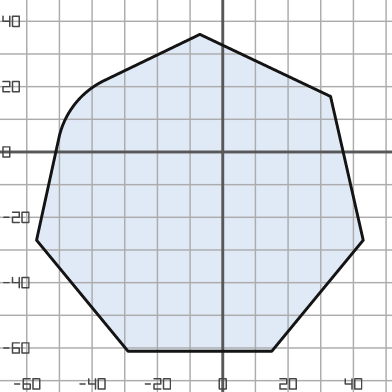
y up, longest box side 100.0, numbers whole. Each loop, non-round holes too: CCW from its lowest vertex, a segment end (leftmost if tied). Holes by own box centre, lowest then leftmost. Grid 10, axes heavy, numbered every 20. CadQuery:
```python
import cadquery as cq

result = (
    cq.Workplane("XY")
    .moveTo(-29.0, -61.0)
    .lineTo(15.0, -61.0)
    .lineTo(43.0, -27.0)
    .lineTo(33.0, 17.0)
    .lineTo(-7.0, 36.0)
    .lineTo(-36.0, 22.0)
    .threePointArc((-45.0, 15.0), (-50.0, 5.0))
    .lineTo(-57.0, -27.0)
    .close()
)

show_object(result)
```